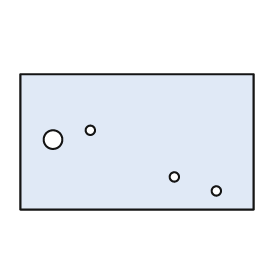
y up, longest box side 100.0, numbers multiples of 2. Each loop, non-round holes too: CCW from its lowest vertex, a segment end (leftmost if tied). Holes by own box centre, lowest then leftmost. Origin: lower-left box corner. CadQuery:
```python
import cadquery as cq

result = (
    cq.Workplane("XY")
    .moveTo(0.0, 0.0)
    .lineTo(100.0, 0.0)
    .lineTo(100.0, 58.0)
    .lineTo(0.0, 58.0)
    .close()
    .moveTo(84.0, 8.0)
    .circle(2.0)
    .moveTo(66.0, 14.0)
    .circle(2.0)
    .moveTo(14.0, 30.0)
    .circle(4.0)
    .moveTo(30.0, 34.0)
    .circle(2.0)
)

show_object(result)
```